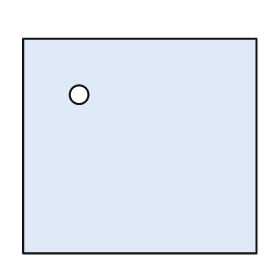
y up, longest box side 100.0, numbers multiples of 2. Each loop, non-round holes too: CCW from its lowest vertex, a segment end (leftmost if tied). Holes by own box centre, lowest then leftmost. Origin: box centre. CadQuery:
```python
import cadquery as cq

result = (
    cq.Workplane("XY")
    .moveTo(-50.0, -46.0)
    .lineTo(50.0, -46.0)
    .lineTo(50.0, 46.0)
    .lineTo(-50.0, 46.0)
    .close()
    .moveTo(-26.0, 22.0)
    .circle(4.0)
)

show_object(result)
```